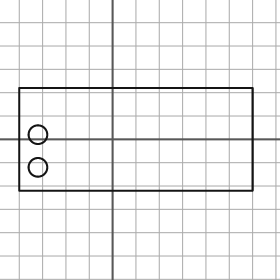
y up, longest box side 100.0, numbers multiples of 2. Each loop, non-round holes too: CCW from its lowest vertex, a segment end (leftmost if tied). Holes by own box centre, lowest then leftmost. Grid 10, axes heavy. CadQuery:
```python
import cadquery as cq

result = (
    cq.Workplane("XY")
    .moveTo(-40.0, -22.0)
    .lineTo(60.0, -22.0)
    .lineTo(60.0, 22.0)
    .lineTo(-40.0, 22.0)
    .close()
    .moveTo(-32.0, -12.0)
    .circle(4.0)
    .moveTo(-32.0, 2.0)
    .circle(4.0)
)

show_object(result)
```